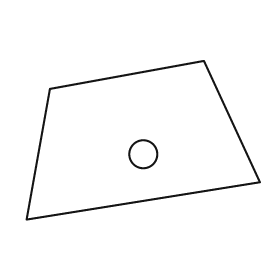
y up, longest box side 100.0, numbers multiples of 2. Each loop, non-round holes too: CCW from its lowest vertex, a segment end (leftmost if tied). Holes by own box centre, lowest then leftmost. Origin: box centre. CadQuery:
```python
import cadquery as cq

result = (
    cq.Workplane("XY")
    .moveTo(-50.0, -34.0)
    .lineTo(50.0, -18.0)
    .lineTo(26.0, 34.0)
    .lineTo(-40.0, 22.0)
    .close()
    .moveTo(0.0, -6.0)
    .circle(6.0)
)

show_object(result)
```